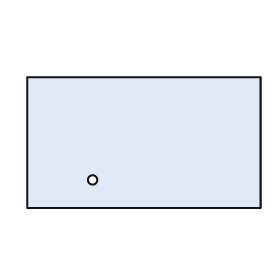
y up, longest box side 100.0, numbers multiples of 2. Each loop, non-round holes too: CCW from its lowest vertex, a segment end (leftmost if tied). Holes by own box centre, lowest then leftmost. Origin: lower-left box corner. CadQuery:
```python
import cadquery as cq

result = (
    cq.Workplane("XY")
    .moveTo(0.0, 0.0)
    .lineTo(100.0, 0.0)
    .lineTo(100.0, 56.0)
    .lineTo(0.0, 56.0)
    .close()
    .moveTo(28.0, 12.0)
    .circle(2.0)
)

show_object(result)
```